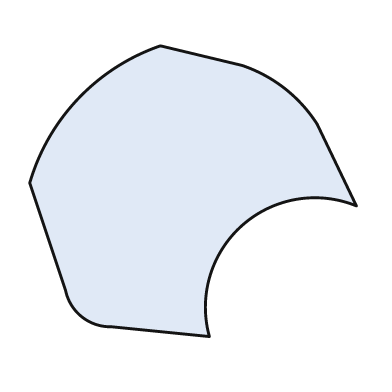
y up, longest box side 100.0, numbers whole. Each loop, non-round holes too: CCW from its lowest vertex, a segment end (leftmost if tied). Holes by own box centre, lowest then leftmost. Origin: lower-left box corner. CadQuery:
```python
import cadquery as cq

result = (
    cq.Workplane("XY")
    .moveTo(55.0, 0.0)
    .threePointArc((65.0, 34.0), (100.0, 40.0))
    .lineTo(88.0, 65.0)
    .threePointArc((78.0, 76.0), (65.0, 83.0))
    .lineTo(40.0, 89.0)
    .threePointArc((15.0, 73.0), (0.0, 47.0))
    .lineTo(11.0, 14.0)
    .threePointArc((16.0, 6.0), (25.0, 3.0))
    .close()
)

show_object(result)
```